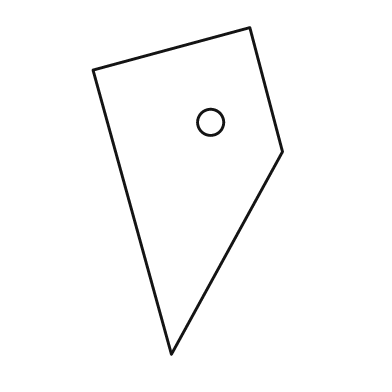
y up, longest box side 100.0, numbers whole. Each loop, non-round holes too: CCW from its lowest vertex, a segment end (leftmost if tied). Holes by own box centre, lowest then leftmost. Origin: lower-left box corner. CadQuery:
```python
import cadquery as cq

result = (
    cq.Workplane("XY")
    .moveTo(24.0, 0.0)
    .lineTo(58.0, 62.0)
    .lineTo(48.0, 100.0)
    .lineTo(0.0, 87.0)
    .close()
    .moveTo(36.0, 71.0)
    .circle(4.0)
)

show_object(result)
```